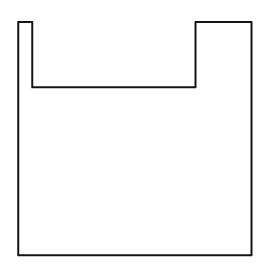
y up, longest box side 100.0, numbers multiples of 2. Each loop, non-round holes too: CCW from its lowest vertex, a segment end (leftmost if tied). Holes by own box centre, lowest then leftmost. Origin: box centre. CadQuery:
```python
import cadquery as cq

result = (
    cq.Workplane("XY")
    .moveTo(-50.0, -50.0)
    .lineTo(50.0, -50.0)
    .lineTo(50.0, 50.0)
    .lineTo(26.0, 50.0)
    .lineTo(26.0, 22.0)
    .lineTo(-44.0, 22.0)
    .lineTo(-44.0, 50.0)
    .lineTo(-50.0, 50.0)
    .close()
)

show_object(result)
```